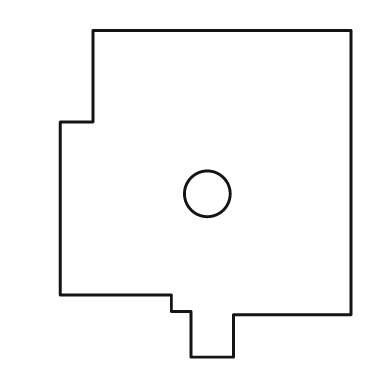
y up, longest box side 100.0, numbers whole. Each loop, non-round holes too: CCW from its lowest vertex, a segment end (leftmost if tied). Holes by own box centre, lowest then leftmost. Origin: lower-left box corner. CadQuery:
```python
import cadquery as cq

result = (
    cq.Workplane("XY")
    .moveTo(40.0, 0.0)
    .lineTo(53.0, 0.0)
    .lineTo(53.0, 13.0)
    .lineTo(89.0, 13.0)
    .lineTo(89.0, 100.0)
    .lineTo(10.0, 100.0)
    .lineTo(10.0, 72.0)
    .lineTo(0.0, 72.0)
    .lineTo(0.0, 19.0)
    .lineTo(34.0, 19.0)
    .lineTo(34.0, 14.0)
    .lineTo(40.0, 14.0)
    .close()
    .moveTo(45.0, 50.0)
    .circle(7.0)
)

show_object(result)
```